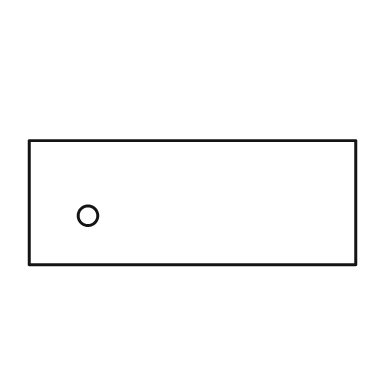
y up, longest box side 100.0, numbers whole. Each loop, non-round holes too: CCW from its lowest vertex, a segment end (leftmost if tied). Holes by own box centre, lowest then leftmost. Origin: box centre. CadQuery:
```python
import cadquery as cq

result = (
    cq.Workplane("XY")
    .moveTo(-50.0, -19.0)
    .lineTo(50.0, -19.0)
    .lineTo(50.0, 19.0)
    .lineTo(-50.0, 19.0)
    .close()
    .moveTo(-32.0, -4.0)
    .circle(3.0)
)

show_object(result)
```